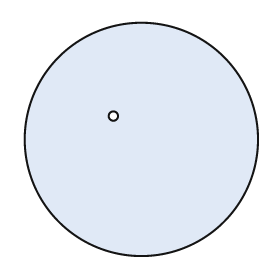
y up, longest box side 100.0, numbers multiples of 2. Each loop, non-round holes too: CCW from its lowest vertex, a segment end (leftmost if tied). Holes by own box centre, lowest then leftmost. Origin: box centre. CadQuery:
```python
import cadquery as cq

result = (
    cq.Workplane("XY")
    .moveTo(0.0, 0.0)
    .circle(50.0)
    .moveTo(-12.0, 10.0)
    .circle(2.0)
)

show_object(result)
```